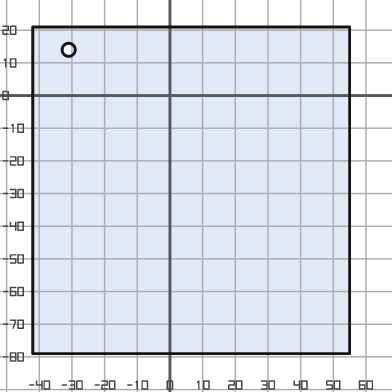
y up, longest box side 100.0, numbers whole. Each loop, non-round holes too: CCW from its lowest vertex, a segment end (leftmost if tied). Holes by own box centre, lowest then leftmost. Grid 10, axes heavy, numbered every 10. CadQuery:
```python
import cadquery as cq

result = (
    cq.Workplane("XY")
    .moveTo(-42.0, -79.0)
    .lineTo(55.0, -79.0)
    .lineTo(55.0, 21.0)
    .lineTo(-42.0, 21.0)
    .close()
    .moveTo(-31.0, 14.0)
    .circle(2.0)
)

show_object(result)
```